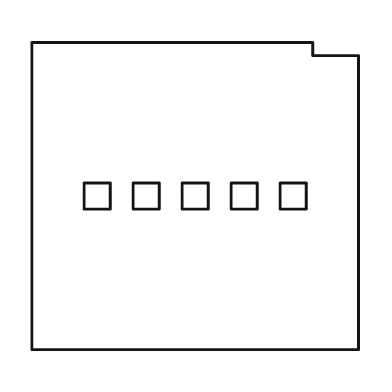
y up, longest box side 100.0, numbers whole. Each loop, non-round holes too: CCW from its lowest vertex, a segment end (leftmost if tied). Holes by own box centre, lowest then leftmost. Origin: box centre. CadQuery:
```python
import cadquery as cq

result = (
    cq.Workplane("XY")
    .moveTo(-50.0, -47.0)
    .lineTo(50.0, -47.0)
    .lineTo(50.0, 43.0)
    .lineTo(36.0, 43.0)
    .lineTo(36.0, 47.0)
    .lineTo(-50.0, 47.0)
    .close()
    .moveTo(-34.0, -4.0)
    .lineTo(-26.0, -4.0)
    .lineTo(-26.0, 4.0)
    .lineTo(-34.0, 4.0)
    .close()
    .moveTo(-19.0, -4.0)
    .lineTo(-11.0, -4.0)
    .lineTo(-11.0, 4.0)
    .lineTo(-19.0, 4.0)
    .close()
    .moveTo(-4.0, -4.0)
    .lineTo(4.0, -4.0)
    .lineTo(4.0, 4.0)
    .lineTo(-4.0, 4.0)
    .close()
    .moveTo(11.0, -4.0)
    .lineTo(19.0, -4.0)
    .lineTo(19.0, 4.0)
    .lineTo(11.0, 4.0)
    .close()
    .moveTo(26.0, -4.0)
    .lineTo(34.0, -4.0)
    .lineTo(34.0, 4.0)
    .lineTo(26.0, 4.0)
    .close()
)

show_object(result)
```